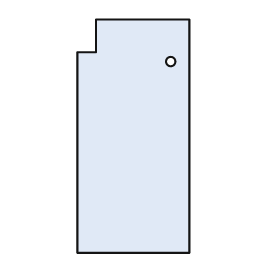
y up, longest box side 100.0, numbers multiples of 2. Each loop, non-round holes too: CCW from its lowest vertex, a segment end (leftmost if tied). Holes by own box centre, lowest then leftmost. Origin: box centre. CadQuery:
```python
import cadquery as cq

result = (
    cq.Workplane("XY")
    .moveTo(-24.0, -50.0)
    .lineTo(24.0, -50.0)
    .lineTo(24.0, 50.0)
    .lineTo(-16.0, 50.0)
    .lineTo(-16.0, 36.0)
    .lineTo(-24.0, 36.0)
    .close()
    .moveTo(16.0, 32.0)
    .circle(2.0)
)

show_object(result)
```